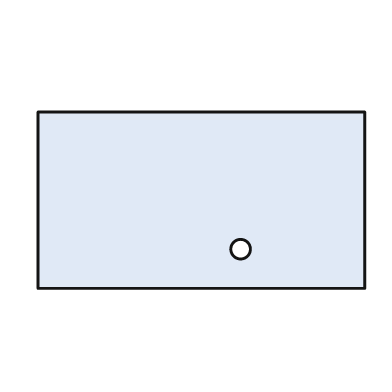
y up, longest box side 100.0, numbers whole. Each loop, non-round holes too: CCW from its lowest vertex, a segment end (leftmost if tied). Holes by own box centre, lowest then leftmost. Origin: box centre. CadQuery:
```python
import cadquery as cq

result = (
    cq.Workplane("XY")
    .moveTo(-50.0, -27.0)
    .lineTo(50.0, -27.0)
    .lineTo(50.0, 27.0)
    .lineTo(-50.0, 27.0)
    .close()
    .moveTo(12.0, -15.0)
    .circle(3.0)
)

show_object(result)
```